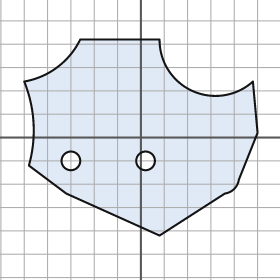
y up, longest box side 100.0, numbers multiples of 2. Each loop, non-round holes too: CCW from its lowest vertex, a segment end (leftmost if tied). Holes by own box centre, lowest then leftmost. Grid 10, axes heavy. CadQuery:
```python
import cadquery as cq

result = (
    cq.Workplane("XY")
    .moveTo(8.0, -42.0)
    .lineTo(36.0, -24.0)
    .threePointArc((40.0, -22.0), (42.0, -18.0))
    .lineTo(50.0, 2.0)
    .lineTo(48.0, 24.0)
    .threePointArc((22.0, 20.0), (8.0, 42.0))
    .lineTo(-26.0, 42.0)
    .threePointArc((-36.0, 30.0), (-50.0, 24.0))
    .threePointArc((-46.0, 6.0), (-48.0, -12.0))
    .lineTo(-32.0, -24.0)
    .close()
    .moveTo(-30.0, -10.0)
    .circle(4.0)
    .moveTo(2.0, -10.0)
    .circle(4.0)
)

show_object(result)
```